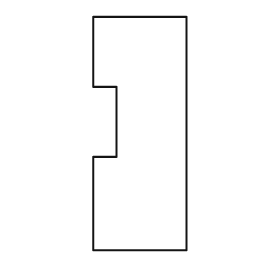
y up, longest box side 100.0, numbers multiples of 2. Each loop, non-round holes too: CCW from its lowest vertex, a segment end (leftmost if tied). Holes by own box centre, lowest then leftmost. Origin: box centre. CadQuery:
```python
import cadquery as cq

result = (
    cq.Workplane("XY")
    .moveTo(-20.0, -50.0)
    .lineTo(20.0, -50.0)
    .lineTo(20.0, 50.0)
    .lineTo(-20.0, 50.0)
    .lineTo(-20.0, 20.0)
    .lineTo(-10.0, 20.0)
    .lineTo(-10.0, -10.0)
    .lineTo(-20.0, -10.0)
    .close()
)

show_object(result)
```